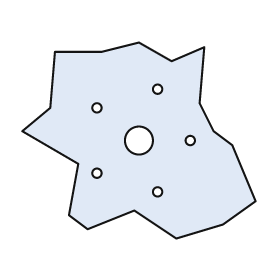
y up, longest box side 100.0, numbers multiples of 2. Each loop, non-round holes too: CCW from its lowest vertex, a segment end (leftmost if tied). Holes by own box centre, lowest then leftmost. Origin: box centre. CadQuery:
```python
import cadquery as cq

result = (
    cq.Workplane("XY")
    .moveTo(16.0, -42.0)
    .lineTo(36.0, -36.0)
    .lineTo(50.0, -26.0)
    .lineTo(40.0, -2.0)
    .lineTo(32.0, 4.0)
    .lineTo(26.0, 16.0)
    .lineTo(28.0, 40.0)
    .lineTo(14.0, 34.0)
    .lineTo(0.0, 42.0)
    .lineTo(-16.0, 38.0)
    .lineTo(-36.0, 38.0)
    .lineTo(-38.0, 14.0)
    .lineTo(-50.0, 4.0)
    .lineTo(-26.0, -10.0)
    .lineTo(-30.0, -32.0)
    .lineTo(-22.0, -38.0)
    .lineTo(-2.0, -30.0)
    .close()
    .moveTo(8.0, -22.0)
    .circle(2.0)
    .moveTo(-18.0, -14.0)
    .circle(2.0)
    .moveTo(0.0, 0.0)
    .circle(6.0)
    .moveTo(22.0, 0.0)
    .circle(2.0)
    .moveTo(-18.0, 14.0)
    .circle(2.0)
    .moveTo(8.0, 22.0)
    .circle(2.0)
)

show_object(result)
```